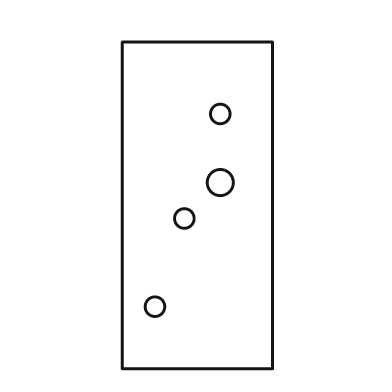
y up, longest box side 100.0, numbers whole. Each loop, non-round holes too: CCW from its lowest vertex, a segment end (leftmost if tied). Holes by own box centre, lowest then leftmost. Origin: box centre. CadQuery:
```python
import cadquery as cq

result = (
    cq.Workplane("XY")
    .moveTo(-23.0, -50.0)
    .lineTo(23.0, -50.0)
    .lineTo(23.0, 50.0)
    .lineTo(-23.0, 50.0)
    .close()
    .moveTo(-13.0, -31.0)
    .circle(3.0)
    .moveTo(-4.0, -4.0)
    .circle(3.0)
    .moveTo(7.0, 7.0)
    .circle(4.0)
    .moveTo(7.0, 28.0)
    .circle(3.0)
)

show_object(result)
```